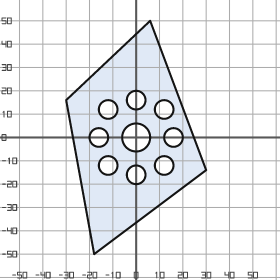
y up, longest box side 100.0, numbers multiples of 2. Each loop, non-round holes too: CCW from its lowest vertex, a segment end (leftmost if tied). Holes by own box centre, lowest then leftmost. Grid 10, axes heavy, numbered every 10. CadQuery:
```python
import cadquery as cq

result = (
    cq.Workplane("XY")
    .moveTo(-18.0, -50.0)
    .lineTo(30.0, -14.0)
    .lineTo(6.0, 50.0)
    .lineTo(-30.0, 16.0)
    .close()
    .moveTo(0.0, -16.0)
    .circle(4.0)
    .moveTo(-12.0, -12.0)
    .circle(4.0)
    .moveTo(12.0, -12.0)
    .circle(4.0)
    .moveTo(-16.0, 0.0)
    .circle(4.0)
    .moveTo(0.0, 0.0)
    .circle(6.0)
    .moveTo(16.0, 0.0)
    .circle(4.0)
    .moveTo(-12.0, 12.0)
    .circle(4.0)
    .moveTo(12.0, 12.0)
    .circle(4.0)
    .moveTo(0.0, 16.0)
    .circle(4.0)
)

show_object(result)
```